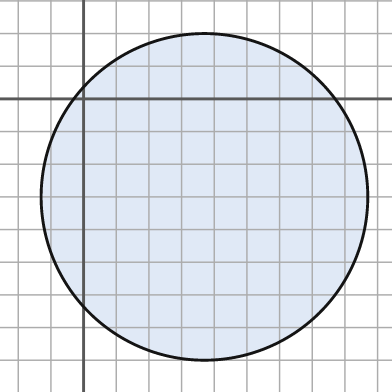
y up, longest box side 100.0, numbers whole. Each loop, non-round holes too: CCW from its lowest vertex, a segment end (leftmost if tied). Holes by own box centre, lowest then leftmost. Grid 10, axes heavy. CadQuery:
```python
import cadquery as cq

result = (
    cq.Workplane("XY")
    .moveTo(37.0, -30.0)
    .circle(50.0)
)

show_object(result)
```